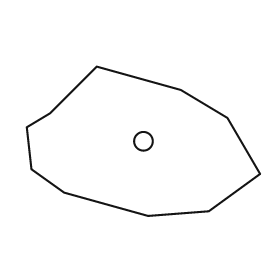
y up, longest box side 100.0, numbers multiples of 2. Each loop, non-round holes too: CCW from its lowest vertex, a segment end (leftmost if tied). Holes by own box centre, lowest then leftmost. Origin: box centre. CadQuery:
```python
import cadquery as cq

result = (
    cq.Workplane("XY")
    .moveTo(2.0, -32.0)
    .lineTo(28.0, -30.0)
    .lineTo(50.0, -14.0)
    .lineTo(36.0, 10.0)
    .lineTo(16.0, 22.0)
    .lineTo(-20.0, 32.0)
    .lineTo(-40.0, 12.0)
    .lineTo(-50.0, 6.0)
    .lineTo(-48.0, -12.0)
    .lineTo(-34.0, -22.0)
    .close()
    .moveTo(0.0, 0.0)
    .circle(4.0)
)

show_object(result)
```